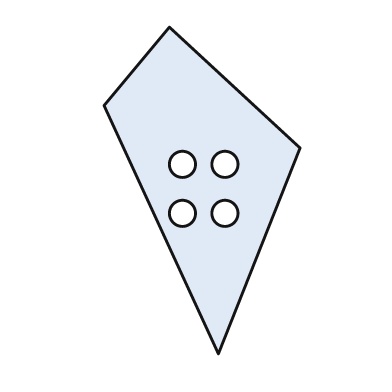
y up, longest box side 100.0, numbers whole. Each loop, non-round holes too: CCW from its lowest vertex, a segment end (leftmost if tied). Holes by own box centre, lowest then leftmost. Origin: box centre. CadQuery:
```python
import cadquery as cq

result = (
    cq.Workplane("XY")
    .moveTo(5.0, -50.0)
    .lineTo(30.0, 13.0)
    .lineTo(-10.0, 50.0)
    .lineTo(-30.0, 26.0)
    .close()
    .moveTo(-6.0, -7.0)
    .circle(4.0)
    .moveTo(7.0, -7.0)
    .circle(4.0)
    .moveTo(-6.0, 8.0)
    .circle(4.0)
    .moveTo(7.0, 8.0)
    .circle(4.0)
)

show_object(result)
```